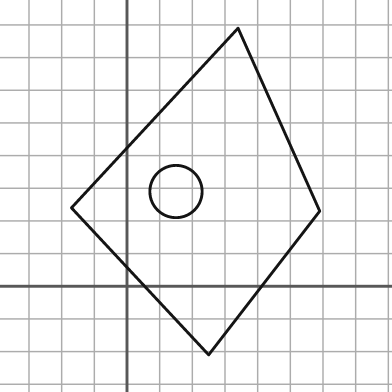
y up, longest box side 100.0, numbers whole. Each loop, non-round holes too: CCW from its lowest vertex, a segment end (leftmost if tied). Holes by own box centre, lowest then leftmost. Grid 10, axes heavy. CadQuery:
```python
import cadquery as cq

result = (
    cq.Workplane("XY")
    .moveTo(25.0, -21.0)
    .lineTo(59.0, 23.0)
    .lineTo(34.0, 79.0)
    .lineTo(-17.0, 24.0)
    .close()
    .moveTo(15.0, 29.0)
    .circle(8.0)
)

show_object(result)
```